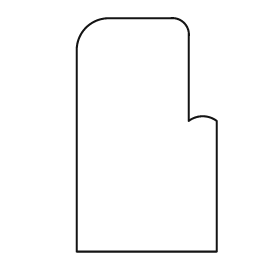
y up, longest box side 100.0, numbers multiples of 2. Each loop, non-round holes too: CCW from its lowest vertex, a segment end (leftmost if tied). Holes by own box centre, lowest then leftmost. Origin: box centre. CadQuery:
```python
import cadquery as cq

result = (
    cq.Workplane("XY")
    .moveTo(-30.0, -50.0)
    .lineTo(30.0, -50.0)
    .lineTo(30.0, 6.0)
    .threePointArc((24.0, 8.0), (18.0, 6.0))
    .lineTo(18.0, 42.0)
    .threePointArc((16.0, 48.0), (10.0, 50.0))
    .lineTo(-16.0, 50.0)
    .threePointArc((-26.0, 46.0), (-30.0, 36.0))
    .close()
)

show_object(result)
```